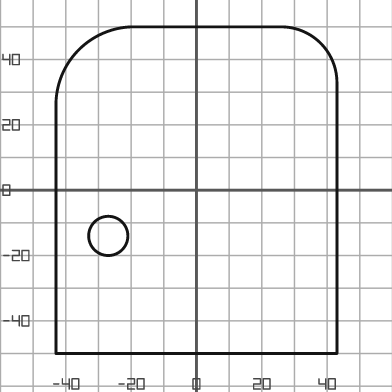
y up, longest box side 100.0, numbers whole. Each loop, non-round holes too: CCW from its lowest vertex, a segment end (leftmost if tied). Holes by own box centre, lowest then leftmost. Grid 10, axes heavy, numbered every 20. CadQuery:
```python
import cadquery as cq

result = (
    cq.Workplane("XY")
    .moveTo(-43.0, -50.0)
    .lineTo(43.0, -50.0)
    .lineTo(43.0, 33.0)
    .threePointArc((38.0, 45.0), (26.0, 50.0))
    .lineTo(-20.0, 50.0)
    .threePointArc((-36.0, 43.0), (-43.0, 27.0))
    .close()
    .moveTo(-27.0, -14.0)
    .circle(6.0)
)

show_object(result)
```